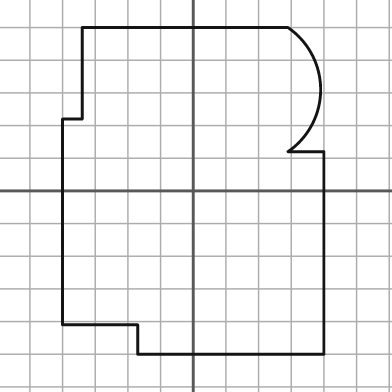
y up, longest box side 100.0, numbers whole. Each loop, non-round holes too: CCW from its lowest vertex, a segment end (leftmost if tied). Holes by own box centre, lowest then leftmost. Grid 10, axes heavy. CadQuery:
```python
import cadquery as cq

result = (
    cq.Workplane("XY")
    .moveTo(-17.0, -50.0)
    .lineTo(40.0, -50.0)
    .lineTo(40.0, 12.0)
    .lineTo(29.0, 12.0)
    .threePointArc((39.0, 31.0), (29.0, 50.0))
    .lineTo(-34.0, 50.0)
    .lineTo(-34.0, 22.0)
    .lineTo(-40.0, 22.0)
    .lineTo(-40.0, -41.0)
    .lineTo(-17.0, -41.0)
    .close()
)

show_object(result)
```